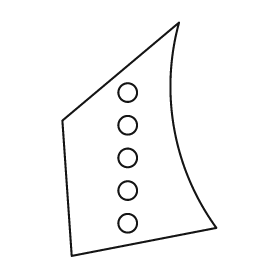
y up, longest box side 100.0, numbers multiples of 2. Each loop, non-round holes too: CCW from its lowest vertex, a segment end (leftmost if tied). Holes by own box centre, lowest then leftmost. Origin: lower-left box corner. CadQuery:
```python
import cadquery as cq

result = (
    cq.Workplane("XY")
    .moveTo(4.0, 0.0)
    .lineTo(66.0, 12.0)
    .threePointArc((48.0, 54.0), (50.0, 100.0))
    .lineTo(0.0, 58.0)
    .close()
    .moveTo(28.0, 14.0)
    .circle(4.0)
    .moveTo(28.0, 28.0)
    .circle(4.0)
    .moveTo(28.0, 42.0)
    .circle(4.0)
    .moveTo(28.0, 56.0)
    .circle(4.0)
    .moveTo(28.0, 70.0)
    .circle(4.0)
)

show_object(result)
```